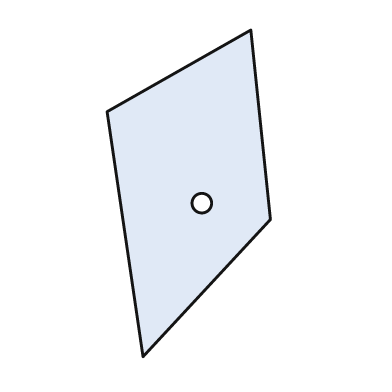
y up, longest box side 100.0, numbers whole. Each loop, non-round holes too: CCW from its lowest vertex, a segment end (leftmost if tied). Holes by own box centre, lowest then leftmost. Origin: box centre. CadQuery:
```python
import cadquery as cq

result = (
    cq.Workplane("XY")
    .moveTo(-14.0, -50.0)
    .lineTo(25.0, -8.0)
    .lineTo(19.0, 50.0)
    .lineTo(-25.0, 25.0)
    .close()
    .moveTo(4.0, -3.0)
    .circle(3.0)
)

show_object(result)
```